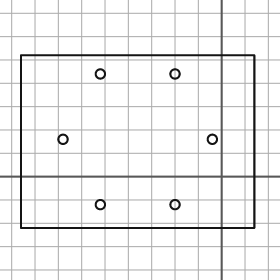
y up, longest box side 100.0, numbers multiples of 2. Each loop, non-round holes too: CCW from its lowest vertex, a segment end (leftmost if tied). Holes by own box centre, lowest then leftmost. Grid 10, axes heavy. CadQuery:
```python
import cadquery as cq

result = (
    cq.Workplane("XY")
    .moveTo(-86.0, -22.0)
    .lineTo(14.0, -22.0)
    .lineTo(14.0, 52.0)
    .lineTo(-86.0, 52.0)
    .close()
    .moveTo(-52.0, -12.0)
    .circle(2.0)
    .moveTo(-20.0, -12.0)
    .circle(2.0)
    .moveTo(-68.0, 16.0)
    .circle(2.0)
    .moveTo(-4.0, 16.0)
    .circle(2.0)
    .moveTo(-52.0, 44.0)
    .circle(2.0)
    .moveTo(-20.0, 44.0)
    .circle(2.0)
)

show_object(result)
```